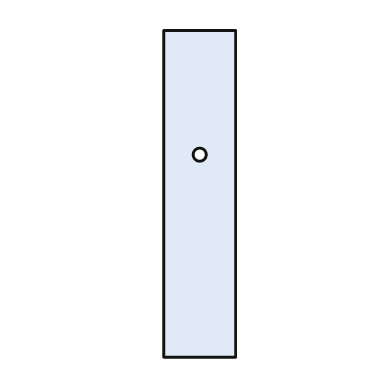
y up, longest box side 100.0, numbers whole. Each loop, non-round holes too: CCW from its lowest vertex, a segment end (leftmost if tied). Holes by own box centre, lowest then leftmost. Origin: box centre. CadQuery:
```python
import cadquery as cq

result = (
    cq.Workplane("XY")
    .moveTo(-11.0, -50.0)
    .lineTo(11.0, -50.0)
    .lineTo(11.0, 50.0)
    .lineTo(-11.0, 50.0)
    .close()
    .moveTo(0.0, 12.0)
    .circle(2.0)
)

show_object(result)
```